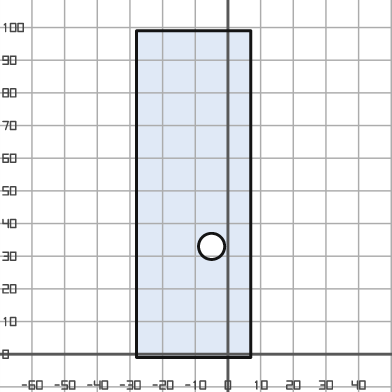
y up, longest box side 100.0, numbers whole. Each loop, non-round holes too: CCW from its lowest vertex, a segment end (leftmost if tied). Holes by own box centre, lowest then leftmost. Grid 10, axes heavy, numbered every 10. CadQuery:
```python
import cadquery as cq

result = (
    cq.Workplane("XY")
    .moveTo(-28.0, -1.0)
    .lineTo(7.0, -1.0)
    .lineTo(7.0, 99.0)
    .lineTo(-28.0, 99.0)
    .close()
    .moveTo(-5.0, 33.0)
    .circle(4.0)
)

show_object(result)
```